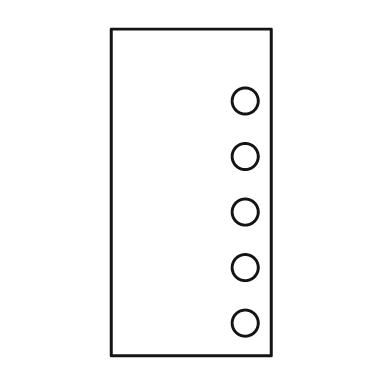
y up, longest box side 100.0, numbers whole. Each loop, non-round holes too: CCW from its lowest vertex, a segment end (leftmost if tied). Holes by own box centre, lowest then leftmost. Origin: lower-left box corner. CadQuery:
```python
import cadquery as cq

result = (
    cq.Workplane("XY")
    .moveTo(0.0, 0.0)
    .lineTo(49.0, 0.0)
    .lineTo(49.0, 100.0)
    .lineTo(0.0, 100.0)
    .close()
    .moveTo(41.0, 10.0)
    .circle(4.0)
    .moveTo(41.0, 27.0)
    .circle(4.0)
    .moveTo(41.0, 44.0)
    .circle(4.0)
    .moveTo(41.0, 61.0)
    .circle(4.0)
    .moveTo(41.0, 78.0)
    .circle(4.0)
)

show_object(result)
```